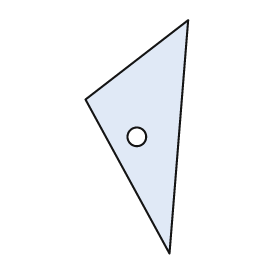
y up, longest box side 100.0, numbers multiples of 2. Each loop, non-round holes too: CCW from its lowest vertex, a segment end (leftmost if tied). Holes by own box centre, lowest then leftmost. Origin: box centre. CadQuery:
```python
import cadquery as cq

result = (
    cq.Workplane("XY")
    .moveTo(14.0, -50.0)
    .lineTo(22.0, 50.0)
    .lineTo(-22.0, 16.0)
    .close()
    .moveTo(0.0, 0.0)
    .circle(4.0)
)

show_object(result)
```